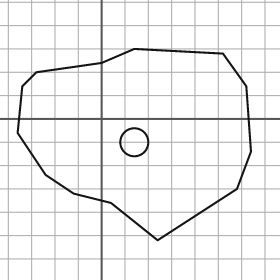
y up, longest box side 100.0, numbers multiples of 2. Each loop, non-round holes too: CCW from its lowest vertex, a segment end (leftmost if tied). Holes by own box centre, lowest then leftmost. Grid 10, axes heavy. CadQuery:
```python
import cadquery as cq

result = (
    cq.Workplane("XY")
    .moveTo(24.0, -52.0)
    .lineTo(58.0, -30.0)
    .lineTo(64.0, -14.0)
    .lineTo(62.0, 14.0)
    .lineTo(52.0, 28.0)
    .lineTo(14.0, 30.0)
    .lineTo(0.0, 24.0)
    .lineTo(-28.0, 20.0)
    .lineTo(-34.0, 14.0)
    .lineTo(-36.0, -6.0)
    .lineTo(-24.0, -24.0)
    .lineTo(-12.0, -32.0)
    .lineTo(4.0, -36.0)
    .close()
    .moveTo(14.0, -10.0)
    .circle(6.0)
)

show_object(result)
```